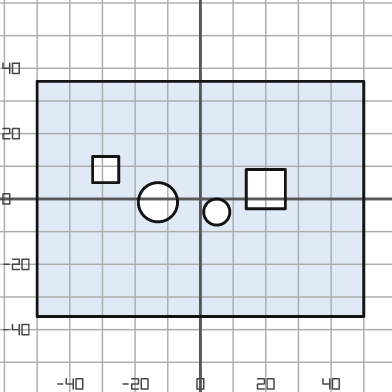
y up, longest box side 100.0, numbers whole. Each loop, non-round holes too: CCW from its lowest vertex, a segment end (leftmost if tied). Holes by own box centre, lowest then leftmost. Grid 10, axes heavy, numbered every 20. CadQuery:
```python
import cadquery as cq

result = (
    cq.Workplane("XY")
    .moveTo(-50.0, -36.0)
    .lineTo(50.0, -36.0)
    .lineTo(50.0, 36.0)
    .lineTo(-50.0, 36.0)
    .close()
    .moveTo(5.0, -4.0)
    .circle(4.0)
    .moveTo(-13.0, -1.0)
    .circle(6.0)
    .moveTo(14.0, -3.0)
    .lineTo(26.0, -3.0)
    .lineTo(26.0, 9.0)
    .lineTo(14.0, 9.0)
    .close()
    .moveTo(-33.0, 5.0)
    .lineTo(-25.0, 5.0)
    .lineTo(-25.0, 13.0)
    .lineTo(-33.0, 13.0)
    .close()
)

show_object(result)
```